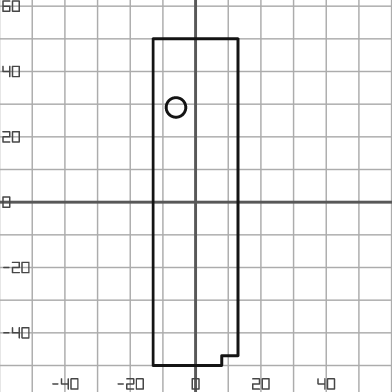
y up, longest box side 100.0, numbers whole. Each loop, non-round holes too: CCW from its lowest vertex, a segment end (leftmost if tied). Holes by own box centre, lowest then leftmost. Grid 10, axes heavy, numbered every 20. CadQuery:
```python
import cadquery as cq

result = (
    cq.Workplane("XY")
    .moveTo(-13.0, -50.0)
    .lineTo(8.0, -50.0)
    .lineTo(8.0, -47.0)
    .lineTo(13.0, -47.0)
    .lineTo(13.0, 50.0)
    .lineTo(-13.0, 50.0)
    .close()
    .moveTo(-6.0, 29.0)
    .circle(3.0)
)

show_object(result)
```